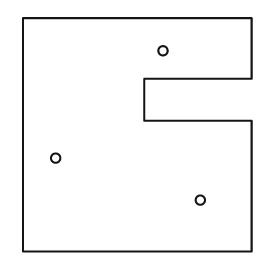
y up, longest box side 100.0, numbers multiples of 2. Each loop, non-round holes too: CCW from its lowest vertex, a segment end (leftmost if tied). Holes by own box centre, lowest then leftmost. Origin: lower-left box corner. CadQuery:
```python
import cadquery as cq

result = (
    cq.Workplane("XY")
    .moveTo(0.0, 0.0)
    .lineTo(98.0, 0.0)
    .lineTo(98.0, 56.0)
    .lineTo(52.0, 56.0)
    .lineTo(52.0, 74.0)
    .lineTo(98.0, 74.0)
    .lineTo(98.0, 100.0)
    .lineTo(0.0, 100.0)
    .close()
    .moveTo(76.0, 22.0)
    .circle(2.0)
    .moveTo(14.0, 40.0)
    .circle(2.0)
    .moveTo(60.0, 86.0)
    .circle(2.0)
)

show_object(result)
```